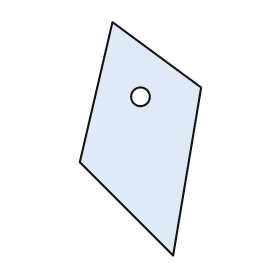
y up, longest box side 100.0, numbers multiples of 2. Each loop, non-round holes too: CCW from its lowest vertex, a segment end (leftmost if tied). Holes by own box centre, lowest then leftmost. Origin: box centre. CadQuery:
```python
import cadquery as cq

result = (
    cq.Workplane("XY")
    .moveTo(14.0, -50.0)
    .lineTo(26.0, 22.0)
    .lineTo(-12.0, 50.0)
    .lineTo(-26.0, -10.0)
    .close()
    .moveTo(0.0, 18.0)
    .circle(4.0)
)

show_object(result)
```